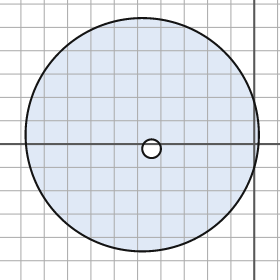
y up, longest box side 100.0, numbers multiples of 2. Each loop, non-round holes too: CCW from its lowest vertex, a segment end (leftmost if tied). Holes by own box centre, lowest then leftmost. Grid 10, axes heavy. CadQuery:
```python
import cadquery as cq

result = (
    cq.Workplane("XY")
    .moveTo(-48.0, 4.0)
    .circle(50.0)
    .moveTo(-44.0, -2.0)
    .circle(4.0)
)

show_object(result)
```